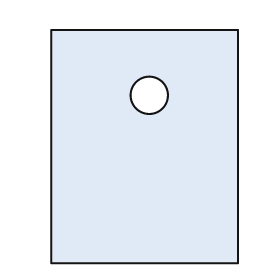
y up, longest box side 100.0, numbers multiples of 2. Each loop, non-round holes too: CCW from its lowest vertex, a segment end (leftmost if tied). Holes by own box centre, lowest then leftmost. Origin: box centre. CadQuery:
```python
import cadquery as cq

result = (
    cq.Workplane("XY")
    .moveTo(-40.0, -50.0)
    .lineTo(40.0, -50.0)
    .lineTo(40.0, 50.0)
    .lineTo(-40.0, 50.0)
    .close()
    .moveTo(2.0, 22.0)
    .circle(8.0)
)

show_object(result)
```